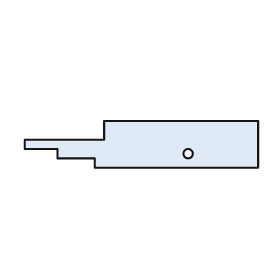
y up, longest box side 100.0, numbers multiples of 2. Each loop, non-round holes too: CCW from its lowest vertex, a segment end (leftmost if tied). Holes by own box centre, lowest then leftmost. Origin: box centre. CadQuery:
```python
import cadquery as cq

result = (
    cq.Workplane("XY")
    .moveTo(-20.0, -10.0)
    .lineTo(50.0, -10.0)
    .lineTo(50.0, 10.0)
    .lineTo(-16.0, 10.0)
    .lineTo(-16.0, 2.0)
    .lineTo(-50.0, 2.0)
    .lineTo(-50.0, -2.0)
    .lineTo(-36.0, -2.0)
    .lineTo(-36.0, -6.0)
    .lineTo(-20.0, -6.0)
    .close()
    .moveTo(20.0, -4.0)
    .circle(2.0)
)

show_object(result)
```